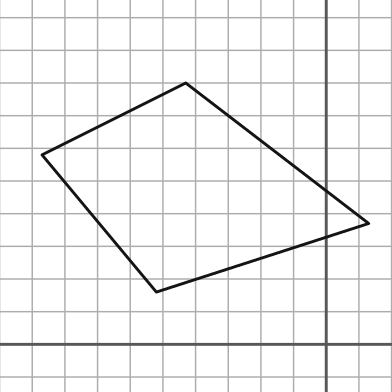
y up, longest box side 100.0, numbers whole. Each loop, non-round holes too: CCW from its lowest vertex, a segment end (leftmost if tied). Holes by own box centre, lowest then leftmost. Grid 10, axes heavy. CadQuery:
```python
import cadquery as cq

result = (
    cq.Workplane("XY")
    .moveTo(-52.0, 16.0)
    .lineTo(13.0, 37.0)
    .lineTo(-43.0, 80.0)
    .lineTo(-87.0, 58.0)
    .close()
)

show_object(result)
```